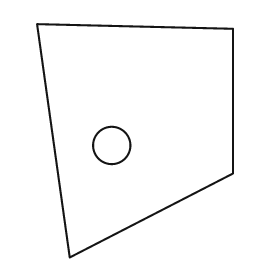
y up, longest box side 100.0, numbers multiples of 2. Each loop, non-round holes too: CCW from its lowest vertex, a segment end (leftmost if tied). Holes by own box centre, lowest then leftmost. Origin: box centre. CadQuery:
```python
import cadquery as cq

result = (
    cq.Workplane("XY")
    .moveTo(-28.0, -50.0)
    .lineTo(42.0, -14.0)
    .lineTo(42.0, 48.0)
    .lineTo(-42.0, 50.0)
    .close()
    .moveTo(-10.0, -2.0)
    .circle(8.0)
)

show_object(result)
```